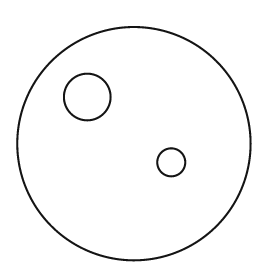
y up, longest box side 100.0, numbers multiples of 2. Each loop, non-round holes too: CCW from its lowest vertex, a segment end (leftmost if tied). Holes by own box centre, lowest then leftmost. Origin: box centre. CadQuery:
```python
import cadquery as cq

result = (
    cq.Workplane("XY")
    .moveTo(0.0, 0.0)
    .circle(50.0)
    .moveTo(16.0, -8.0)
    .circle(6.0)
    .moveTo(-20.0, 20.0)
    .circle(10.0)
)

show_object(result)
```